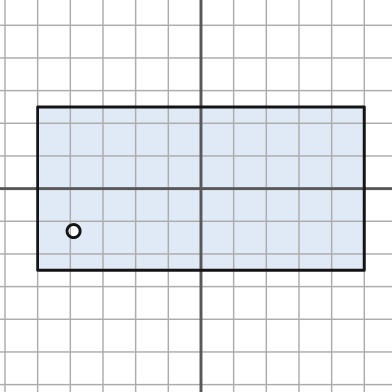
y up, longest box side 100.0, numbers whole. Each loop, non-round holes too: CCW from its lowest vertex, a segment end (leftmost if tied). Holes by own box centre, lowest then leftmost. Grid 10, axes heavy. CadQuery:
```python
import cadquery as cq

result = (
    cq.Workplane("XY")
    .moveTo(-50.0, -25.0)
    .lineTo(50.0, -25.0)
    .lineTo(50.0, 25.0)
    .lineTo(-50.0, 25.0)
    .close()
    .moveTo(-39.0, -13.0)
    .circle(2.0)
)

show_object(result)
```